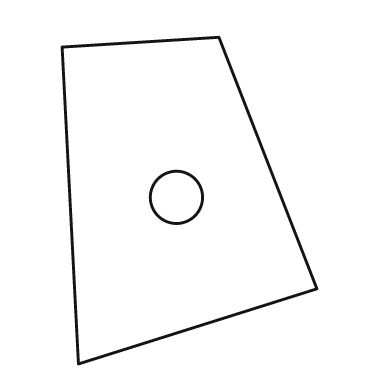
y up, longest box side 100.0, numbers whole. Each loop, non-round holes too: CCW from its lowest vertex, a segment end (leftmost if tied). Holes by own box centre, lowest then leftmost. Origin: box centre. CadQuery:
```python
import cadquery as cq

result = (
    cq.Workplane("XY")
    .moveTo(-34.0, -50.0)
    .lineTo(39.0, -27.0)
    .lineTo(9.0, 50.0)
    .lineTo(-39.0, 47.0)
    .close()
    .moveTo(-4.0, 1.0)
    .circle(8.0)
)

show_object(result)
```